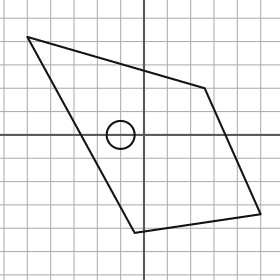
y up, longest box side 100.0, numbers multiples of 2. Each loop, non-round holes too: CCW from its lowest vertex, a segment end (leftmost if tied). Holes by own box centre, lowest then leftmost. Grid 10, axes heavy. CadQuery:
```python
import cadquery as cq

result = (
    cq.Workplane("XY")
    .moveTo(-4.0, -42.0)
    .lineTo(50.0, -34.0)
    .lineTo(26.0, 20.0)
    .lineTo(-50.0, 42.0)
    .close()
    .moveTo(-10.0, 0.0)
    .circle(6.0)
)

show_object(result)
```